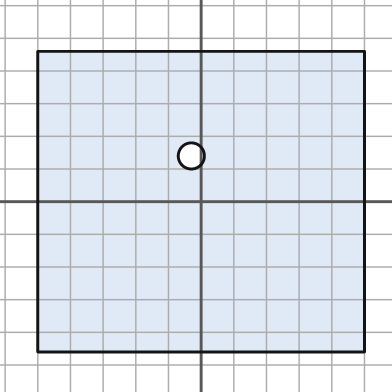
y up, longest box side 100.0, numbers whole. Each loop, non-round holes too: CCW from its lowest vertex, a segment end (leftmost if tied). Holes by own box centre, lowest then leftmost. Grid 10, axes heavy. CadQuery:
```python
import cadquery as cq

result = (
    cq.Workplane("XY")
    .moveTo(-50.0, -46.0)
    .lineTo(50.0, -46.0)
    .lineTo(50.0, 46.0)
    .lineTo(-50.0, 46.0)
    .close()
    .moveTo(-3.0, 14.0)
    .circle(4.0)
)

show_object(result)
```